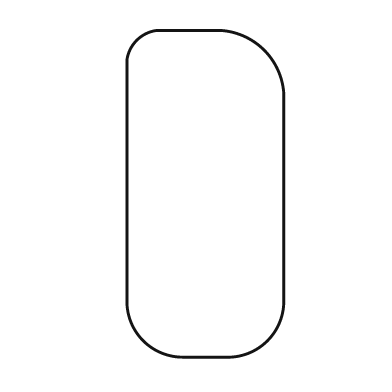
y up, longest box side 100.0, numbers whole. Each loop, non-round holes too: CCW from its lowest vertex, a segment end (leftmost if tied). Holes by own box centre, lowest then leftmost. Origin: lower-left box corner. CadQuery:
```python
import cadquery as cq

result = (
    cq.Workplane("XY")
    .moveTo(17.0, 0.0)
    .lineTo(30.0, 0.0)
    .threePointArc((43.0, 5.0), (48.0, 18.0))
    .lineTo(48.0, 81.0)
    .threePointArc((42.0, 94.0), (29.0, 100.0))
    .lineTo(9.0, 100.0)
    .threePointArc((3.0, 97.0), (0.0, 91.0))
    .lineTo(0.0, 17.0)
    .threePointArc((5.0, 5.0), (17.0, 0.0))
    .close()
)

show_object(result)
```